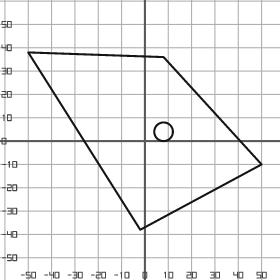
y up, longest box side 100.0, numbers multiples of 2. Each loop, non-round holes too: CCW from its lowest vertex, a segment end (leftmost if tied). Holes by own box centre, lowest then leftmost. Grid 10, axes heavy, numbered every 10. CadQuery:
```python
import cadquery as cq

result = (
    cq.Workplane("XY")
    .moveTo(-2.0, -38.0)
    .lineTo(50.0, -10.0)
    .lineTo(8.0, 36.0)
    .lineTo(-50.0, 38.0)
    .close()
    .moveTo(8.0, 4.0)
    .circle(4.0)
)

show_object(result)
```